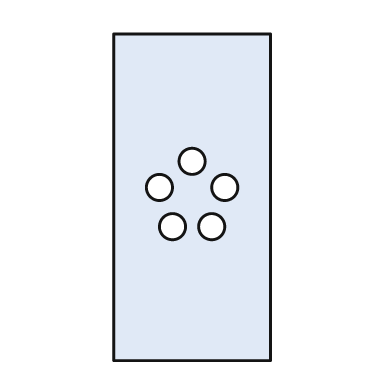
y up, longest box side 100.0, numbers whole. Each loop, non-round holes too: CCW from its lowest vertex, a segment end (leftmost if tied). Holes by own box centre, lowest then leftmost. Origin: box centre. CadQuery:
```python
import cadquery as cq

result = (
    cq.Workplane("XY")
    .moveTo(-24.0, -50.0)
    .lineTo(24.0, -50.0)
    .lineTo(24.0, 50.0)
    .lineTo(-24.0, 50.0)
    .close()
    .moveTo(-6.0, -9.0)
    .circle(4.0)
    .moveTo(6.0, -9.0)
    .circle(4.0)
    .moveTo(-10.0, 3.0)
    .circle(4.0)
    .moveTo(10.0, 3.0)
    .circle(4.0)
    .moveTo(0.0, 11.0)
    .circle(4.0)
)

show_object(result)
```